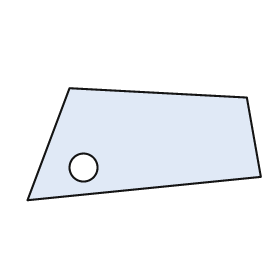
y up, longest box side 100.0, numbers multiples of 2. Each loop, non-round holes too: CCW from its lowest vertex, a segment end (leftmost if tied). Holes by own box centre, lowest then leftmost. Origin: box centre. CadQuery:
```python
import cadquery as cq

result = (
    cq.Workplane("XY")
    .moveTo(-50.0, -24.0)
    .lineTo(50.0, -14.0)
    .lineTo(44.0, 20.0)
    .lineTo(-32.0, 24.0)
    .close()
    .moveTo(-26.0, -10.0)
    .circle(6.0)
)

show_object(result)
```